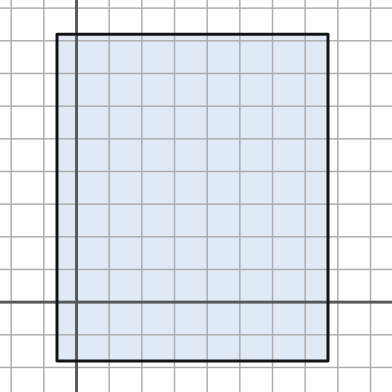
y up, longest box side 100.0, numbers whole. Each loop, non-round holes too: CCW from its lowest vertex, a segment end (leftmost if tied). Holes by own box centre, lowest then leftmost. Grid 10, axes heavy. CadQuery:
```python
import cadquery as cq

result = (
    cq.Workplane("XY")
    .moveTo(-6.0, -18.0)
    .lineTo(77.0, -18.0)
    .lineTo(77.0, 82.0)
    .lineTo(-6.0, 82.0)
    .close()
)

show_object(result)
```